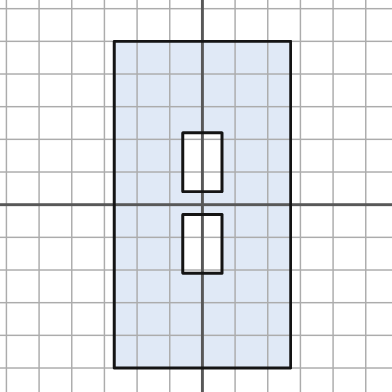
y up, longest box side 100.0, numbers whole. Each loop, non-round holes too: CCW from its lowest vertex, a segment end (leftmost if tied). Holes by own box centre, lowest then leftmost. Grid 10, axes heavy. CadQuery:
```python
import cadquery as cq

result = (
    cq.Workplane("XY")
    .moveTo(-27.0, -50.0)
    .lineTo(27.0, -50.0)
    .lineTo(27.0, 50.0)
    .lineTo(-27.0, 50.0)
    .close()
    .moveTo(-6.0, -21.0)
    .lineTo(6.0, -21.0)
    .lineTo(6.0, -3.0)
    .lineTo(-6.0, -3.0)
    .close()
    .moveTo(-6.0, 4.0)
    .lineTo(6.0, 4.0)
    .lineTo(6.0, 22.0)
    .lineTo(-6.0, 22.0)
    .close()
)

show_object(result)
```